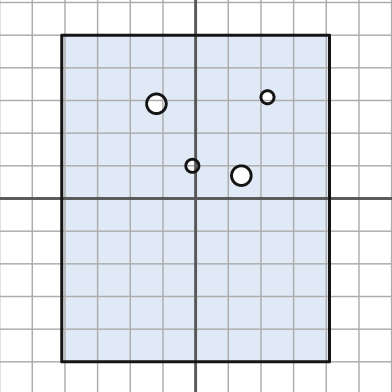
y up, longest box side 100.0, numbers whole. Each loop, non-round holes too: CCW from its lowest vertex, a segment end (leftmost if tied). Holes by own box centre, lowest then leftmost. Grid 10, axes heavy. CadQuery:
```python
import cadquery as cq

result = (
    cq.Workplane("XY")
    .moveTo(-41.0, -50.0)
    .lineTo(41.0, -50.0)
    .lineTo(41.0, 50.0)
    .lineTo(-41.0, 50.0)
    .close()
    .moveTo(14.0, 7.0)
    .circle(3.0)
    .moveTo(-1.0, 10.0)
    .circle(2.0)
    .moveTo(-12.0, 29.0)
    .circle(3.0)
    .moveTo(22.0, 31.0)
    .circle(2.0)
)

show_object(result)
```